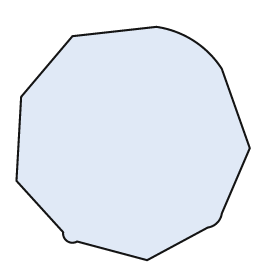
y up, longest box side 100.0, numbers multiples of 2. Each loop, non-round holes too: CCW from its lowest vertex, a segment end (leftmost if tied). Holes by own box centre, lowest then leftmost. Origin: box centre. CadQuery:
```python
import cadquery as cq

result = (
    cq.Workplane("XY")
    .moveTo(6.0, -50.0)
    .lineTo(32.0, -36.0)
    .threePointArc((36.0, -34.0), (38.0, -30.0))
    .lineTo(50.0, -2.0)
    .lineTo(38.0, 32.0)
    .threePointArc((26.0, 44.0), (10.0, 50.0))
    .lineTo(-26.0, 46.0)
    .lineTo(-48.0, 20.0)
    .lineTo(-50.0, -16.0)
    .lineTo(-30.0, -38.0)
    .threePointArc((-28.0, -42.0), (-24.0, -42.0))
    .close()
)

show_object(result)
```